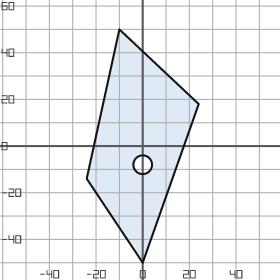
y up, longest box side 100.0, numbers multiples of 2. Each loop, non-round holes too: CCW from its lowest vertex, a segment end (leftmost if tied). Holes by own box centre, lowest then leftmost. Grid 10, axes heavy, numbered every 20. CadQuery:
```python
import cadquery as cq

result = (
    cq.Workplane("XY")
    .moveTo(0.0, -50.0)
    .lineTo(24.0, 18.0)
    .lineTo(-10.0, 50.0)
    .lineTo(-24.0, -14.0)
    .close()
    .moveTo(0.0, -8.0)
    .circle(4.0)
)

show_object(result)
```